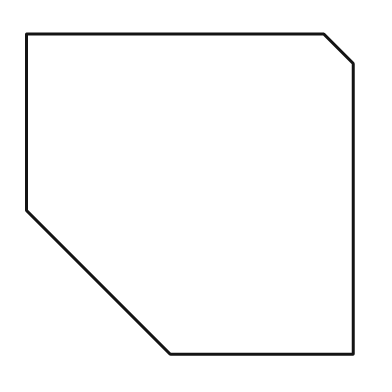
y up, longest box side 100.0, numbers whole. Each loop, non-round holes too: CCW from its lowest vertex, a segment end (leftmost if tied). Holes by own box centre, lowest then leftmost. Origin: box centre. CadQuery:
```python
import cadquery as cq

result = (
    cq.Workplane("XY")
    .moveTo(-6.0, -49.0)
    .lineTo(50.0, -49.0)
    .lineTo(50.0, 40.0)
    .lineTo(41.0, 49.0)
    .lineTo(-50.0, 49.0)
    .lineTo(-50.0, -5.0)
    .close()
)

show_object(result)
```